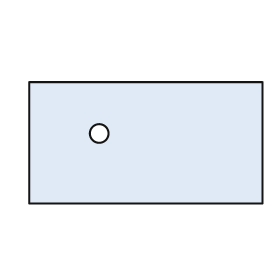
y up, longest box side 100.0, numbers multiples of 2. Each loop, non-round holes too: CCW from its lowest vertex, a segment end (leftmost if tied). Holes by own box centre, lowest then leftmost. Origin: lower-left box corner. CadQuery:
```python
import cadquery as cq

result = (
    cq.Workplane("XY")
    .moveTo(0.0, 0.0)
    .lineTo(100.0, 0.0)
    .lineTo(100.0, 52.0)
    .lineTo(0.0, 52.0)
    .close()
    .moveTo(30.0, 30.0)
    .circle(4.0)
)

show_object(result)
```